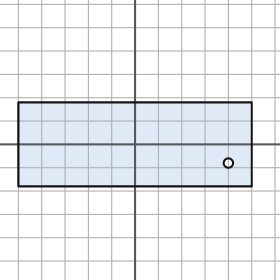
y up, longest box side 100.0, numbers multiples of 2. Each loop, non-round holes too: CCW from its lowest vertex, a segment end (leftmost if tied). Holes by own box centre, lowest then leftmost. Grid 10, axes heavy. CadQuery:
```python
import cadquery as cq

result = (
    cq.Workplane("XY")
    .moveTo(-50.0, -18.0)
    .lineTo(50.0, -18.0)
    .lineTo(50.0, 18.0)
    .lineTo(-50.0, 18.0)
    .close()
    .moveTo(40.0, -8.0)
    .circle(2.0)
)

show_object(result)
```